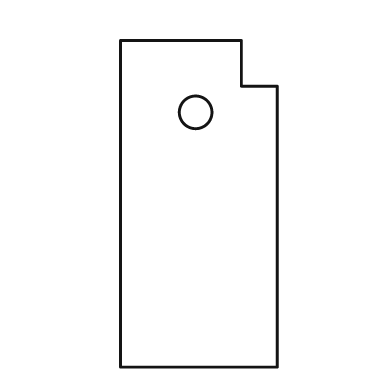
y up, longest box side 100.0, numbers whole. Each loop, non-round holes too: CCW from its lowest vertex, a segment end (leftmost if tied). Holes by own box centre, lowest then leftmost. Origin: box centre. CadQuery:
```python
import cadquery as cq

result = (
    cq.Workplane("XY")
    .moveTo(-24.0, -50.0)
    .lineTo(24.0, -50.0)
    .lineTo(24.0, 36.0)
    .lineTo(13.0, 36.0)
    .lineTo(13.0, 50.0)
    .lineTo(-24.0, 50.0)
    .close()
    .moveTo(-1.0, 28.0)
    .circle(5.0)
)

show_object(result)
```